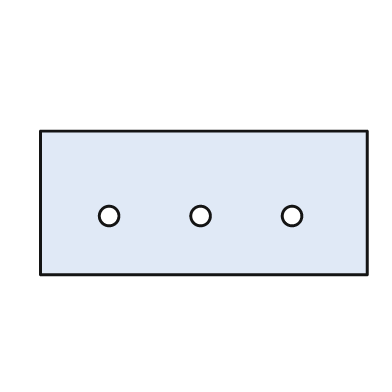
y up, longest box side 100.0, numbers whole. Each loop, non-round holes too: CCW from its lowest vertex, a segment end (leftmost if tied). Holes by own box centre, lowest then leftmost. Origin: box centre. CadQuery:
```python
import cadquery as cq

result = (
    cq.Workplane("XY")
    .moveTo(-50.0, -22.0)
    .lineTo(50.0, -22.0)
    .lineTo(50.0, 22.0)
    .lineTo(-50.0, 22.0)
    .close()
    .moveTo(-29.0, -4.0)
    .circle(3.0)
    .moveTo(-1.0, -4.0)
    .circle(3.0)
    .moveTo(27.0, -4.0)
    .circle(3.0)
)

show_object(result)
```